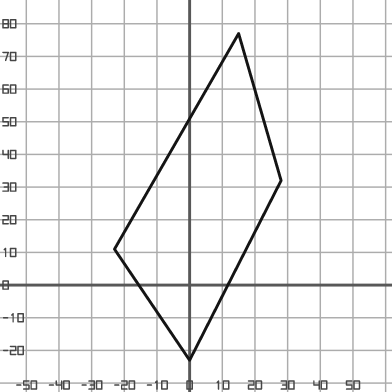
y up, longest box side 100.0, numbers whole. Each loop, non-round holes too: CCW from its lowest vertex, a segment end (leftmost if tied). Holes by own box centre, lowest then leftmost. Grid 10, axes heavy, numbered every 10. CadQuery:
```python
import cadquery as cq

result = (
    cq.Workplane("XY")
    .moveTo(0.0, -23.0)
    .lineTo(28.0, 32.0)
    .lineTo(15.0, 77.0)
    .lineTo(-23.0, 11.0)
    .close()
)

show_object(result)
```